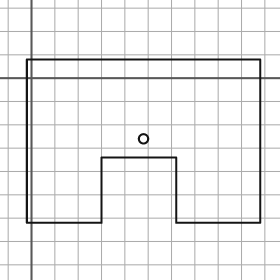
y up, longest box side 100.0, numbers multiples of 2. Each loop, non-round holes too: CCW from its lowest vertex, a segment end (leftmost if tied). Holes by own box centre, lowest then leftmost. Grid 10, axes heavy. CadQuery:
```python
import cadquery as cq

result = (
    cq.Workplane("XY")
    .moveTo(-2.0, -62.0)
    .lineTo(30.0, -62.0)
    .lineTo(30.0, -34.0)
    .lineTo(62.0, -34.0)
    .lineTo(62.0, -62.0)
    .lineTo(98.0, -62.0)
    .lineTo(98.0, 8.0)
    .lineTo(-2.0, 8.0)
    .close()
    .moveTo(48.0, -26.0)
    .circle(2.0)
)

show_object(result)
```